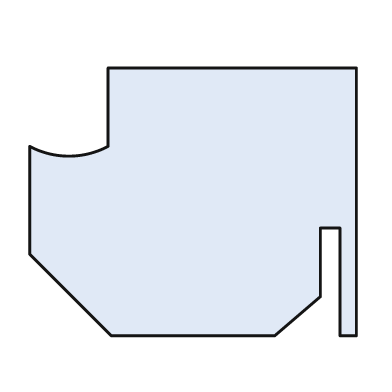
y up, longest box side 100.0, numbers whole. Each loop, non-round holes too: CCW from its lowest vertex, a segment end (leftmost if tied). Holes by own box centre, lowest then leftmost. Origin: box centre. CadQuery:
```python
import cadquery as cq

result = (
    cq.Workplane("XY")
    .moveTo(-25.0, -41.0)
    .lineTo(25.0, -41.0)
    .lineTo(39.0, -29.0)
    .lineTo(39.0, -8.0)
    .lineTo(45.0, -8.0)
    .lineTo(45.0, -41.0)
    .lineTo(50.0, -41.0)
    .lineTo(50.0, 41.0)
    .lineTo(-26.0, 41.0)
    .lineTo(-26.0, 17.0)
    .threePointArc((-38.0, 14.0), (-50.0, 17.0))
    .lineTo(-50.0, -16.0)
    .close()
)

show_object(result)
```